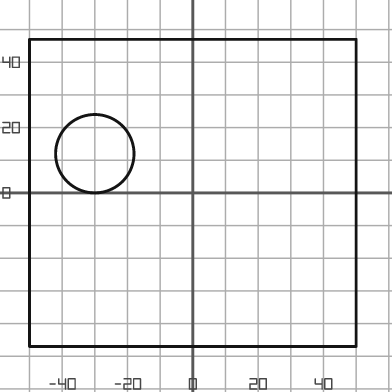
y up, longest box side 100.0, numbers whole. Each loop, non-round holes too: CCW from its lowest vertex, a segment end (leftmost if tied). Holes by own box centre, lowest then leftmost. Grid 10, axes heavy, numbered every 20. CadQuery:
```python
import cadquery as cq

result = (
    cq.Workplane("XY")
    .moveTo(-50.0, -47.0)
    .lineTo(50.0, -47.0)
    .lineTo(50.0, 47.0)
    .lineTo(-50.0, 47.0)
    .close()
    .moveTo(-30.0, 12.0)
    .circle(12.0)
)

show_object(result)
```